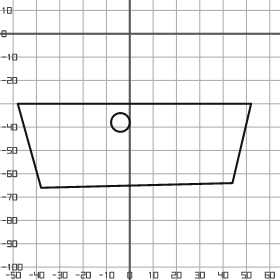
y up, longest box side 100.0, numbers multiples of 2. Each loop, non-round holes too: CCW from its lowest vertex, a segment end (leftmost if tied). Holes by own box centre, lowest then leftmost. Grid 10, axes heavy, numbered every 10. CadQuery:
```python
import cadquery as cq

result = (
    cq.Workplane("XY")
    .moveTo(-38.0, -66.0)
    .lineTo(44.0, -64.0)
    .lineTo(52.0, -30.0)
    .lineTo(-48.0, -30.0)
    .close()
    .moveTo(-4.0, -38.0)
    .circle(4.0)
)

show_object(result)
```